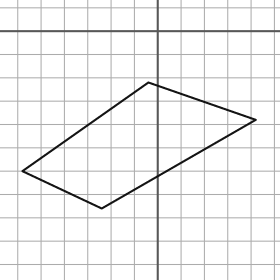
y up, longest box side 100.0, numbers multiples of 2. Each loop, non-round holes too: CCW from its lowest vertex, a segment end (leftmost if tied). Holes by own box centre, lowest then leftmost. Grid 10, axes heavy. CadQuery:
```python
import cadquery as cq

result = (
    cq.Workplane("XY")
    .moveTo(-24.0, -76.0)
    .lineTo(42.0, -38.0)
    .lineTo(-4.0, -22.0)
    .lineTo(-58.0, -60.0)
    .close()
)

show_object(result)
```